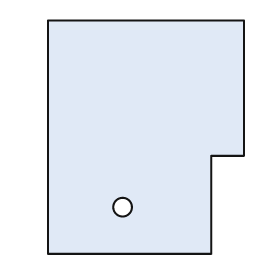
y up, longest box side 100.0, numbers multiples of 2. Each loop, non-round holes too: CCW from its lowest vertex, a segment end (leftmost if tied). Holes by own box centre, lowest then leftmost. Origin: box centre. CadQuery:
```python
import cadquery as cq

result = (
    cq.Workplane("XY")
    .moveTo(-42.0, -50.0)
    .lineTo(28.0, -50.0)
    .lineTo(28.0, -8.0)
    .lineTo(42.0, -8.0)
    .lineTo(42.0, 50.0)
    .lineTo(-42.0, 50.0)
    .close()
    .moveTo(-10.0, -30.0)
    .circle(4.0)
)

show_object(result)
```